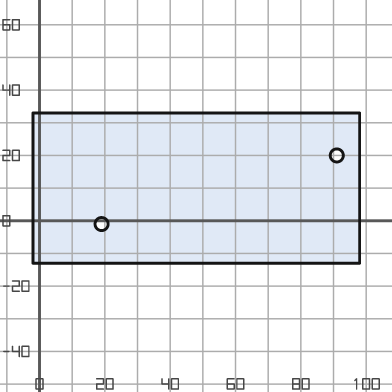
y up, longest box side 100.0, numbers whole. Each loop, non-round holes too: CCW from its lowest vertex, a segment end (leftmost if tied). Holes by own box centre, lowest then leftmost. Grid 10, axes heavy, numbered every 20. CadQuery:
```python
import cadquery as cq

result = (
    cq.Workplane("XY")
    .moveTo(-2.0, -13.0)
    .lineTo(98.0, -13.0)
    .lineTo(98.0, 33.0)
    .lineTo(-2.0, 33.0)
    .close()
    .moveTo(19.0, -1.0)
    .circle(2.0)
    .moveTo(91.0, 20.0)
    .circle(2.0)
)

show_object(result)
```